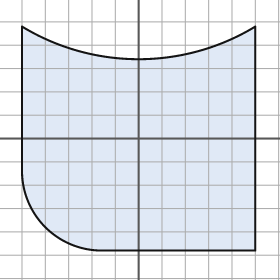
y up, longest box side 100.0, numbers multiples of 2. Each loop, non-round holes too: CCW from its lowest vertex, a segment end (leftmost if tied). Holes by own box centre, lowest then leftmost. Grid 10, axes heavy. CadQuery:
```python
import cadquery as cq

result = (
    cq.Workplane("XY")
    .moveTo(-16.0, -48.0)
    .lineTo(50.0, -48.0)
    .lineTo(50.0, 48.0)
    .threePointArc((0.0, 34.0), (-50.0, 48.0))
    .lineTo(-50.0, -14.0)
    .threePointArc((-40.0, -38.0), (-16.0, -48.0))
    .close()
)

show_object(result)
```